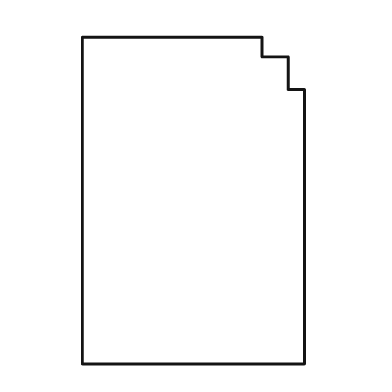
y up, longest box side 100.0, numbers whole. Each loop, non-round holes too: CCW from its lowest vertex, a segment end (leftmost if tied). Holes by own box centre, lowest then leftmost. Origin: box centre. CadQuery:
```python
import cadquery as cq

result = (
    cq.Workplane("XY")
    .moveTo(-34.0, -50.0)
    .lineTo(34.0, -50.0)
    .lineTo(34.0, 34.0)
    .lineTo(29.0, 34.0)
    .lineTo(29.0, 44.0)
    .lineTo(21.0, 44.0)
    .lineTo(21.0, 50.0)
    .lineTo(-34.0, 50.0)
    .close()
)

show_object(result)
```